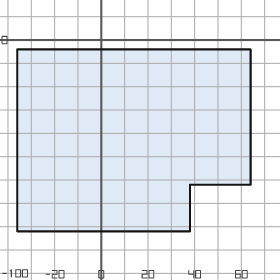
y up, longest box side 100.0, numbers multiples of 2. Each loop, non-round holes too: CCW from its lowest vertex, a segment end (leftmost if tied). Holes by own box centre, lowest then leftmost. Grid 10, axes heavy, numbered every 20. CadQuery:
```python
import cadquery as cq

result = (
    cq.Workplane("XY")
    .moveTo(-36.0, -82.0)
    .lineTo(38.0, -82.0)
    .lineTo(38.0, -62.0)
    .lineTo(64.0, -62.0)
    .lineTo(64.0, -4.0)
    .lineTo(-36.0, -4.0)
    .close()
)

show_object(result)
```